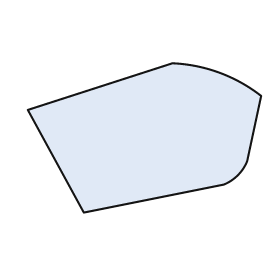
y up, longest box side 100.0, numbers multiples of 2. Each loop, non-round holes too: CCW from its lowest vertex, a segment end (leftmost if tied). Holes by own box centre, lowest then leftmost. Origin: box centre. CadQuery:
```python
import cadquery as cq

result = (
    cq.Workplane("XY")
    .moveTo(-26.0, -32.0)
    .lineTo(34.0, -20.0)
    .threePointArc((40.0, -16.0), (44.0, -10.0))
    .lineTo(50.0, 18.0)
    .threePointArc((32.0, 28.0), (12.0, 32.0))
    .lineTo(-50.0, 12.0)
    .close()
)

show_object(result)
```